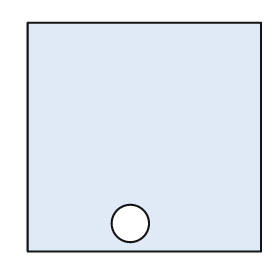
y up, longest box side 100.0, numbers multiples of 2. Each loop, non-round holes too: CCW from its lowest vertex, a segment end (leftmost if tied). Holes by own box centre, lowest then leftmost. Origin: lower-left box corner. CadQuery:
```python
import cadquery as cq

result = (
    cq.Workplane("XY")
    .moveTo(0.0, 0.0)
    .lineTo(100.0, 0.0)
    .lineTo(100.0, 98.0)
    .lineTo(0.0, 98.0)
    .close()
    .moveTo(44.0, 12.0)
    .circle(8.0)
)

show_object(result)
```